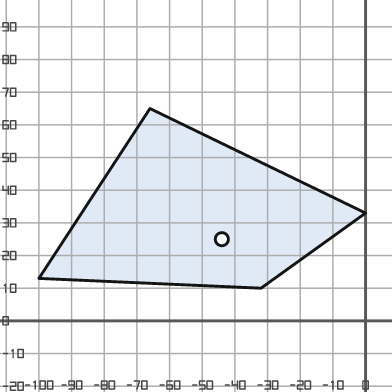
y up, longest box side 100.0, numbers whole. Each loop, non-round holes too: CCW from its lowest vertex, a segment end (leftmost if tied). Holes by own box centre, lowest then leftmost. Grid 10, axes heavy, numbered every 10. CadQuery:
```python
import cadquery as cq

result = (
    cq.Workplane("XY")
    .moveTo(-32.0, 10.0)
    .lineTo(0.0, 33.0)
    .lineTo(-66.0, 65.0)
    .lineTo(-100.0, 13.0)
    .close()
    .moveTo(-44.0, 25.0)
    .circle(2.0)
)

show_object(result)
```